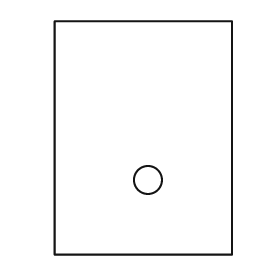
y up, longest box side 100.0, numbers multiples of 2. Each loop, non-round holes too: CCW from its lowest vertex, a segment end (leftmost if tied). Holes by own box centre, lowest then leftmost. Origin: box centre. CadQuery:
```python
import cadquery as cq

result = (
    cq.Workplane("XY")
    .moveTo(-38.0, -50.0)
    .lineTo(38.0, -50.0)
    .lineTo(38.0, 50.0)
    .lineTo(-38.0, 50.0)
    .close()
    .moveTo(2.0, -18.0)
    .circle(6.0)
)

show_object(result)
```